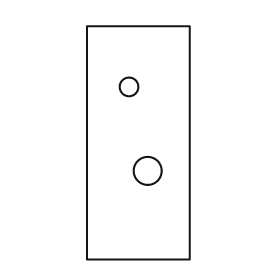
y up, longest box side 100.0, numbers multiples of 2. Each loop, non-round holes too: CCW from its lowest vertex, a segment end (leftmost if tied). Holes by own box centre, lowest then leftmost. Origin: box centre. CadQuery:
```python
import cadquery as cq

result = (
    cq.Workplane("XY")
    .moveTo(-22.0, -50.0)
    .lineTo(22.0, -50.0)
    .lineTo(22.0, 50.0)
    .lineTo(-22.0, 50.0)
    .close()
    .moveTo(4.0, -12.0)
    .circle(6.0)
    .moveTo(-4.0, 24.0)
    .circle(4.0)
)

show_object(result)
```